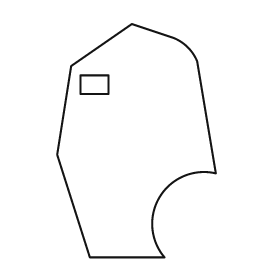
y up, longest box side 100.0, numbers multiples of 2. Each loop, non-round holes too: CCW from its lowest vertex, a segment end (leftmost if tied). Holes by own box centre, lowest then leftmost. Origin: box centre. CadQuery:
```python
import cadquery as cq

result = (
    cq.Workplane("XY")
    .moveTo(-20.0, -50.0)
    .lineTo(12.0, -50.0)
    .threePointArc((10.0, -24.0), (34.0, -14.0))
    .lineTo(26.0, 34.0)
    .threePointArc((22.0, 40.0), (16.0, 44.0))
    .lineTo(-2.0, 50.0)
    .lineTo(-28.0, 32.0)
    .lineTo(-34.0, -6.0)
    .close()
    .moveTo(-24.0, 20.0)
    .lineTo(-12.0, 20.0)
    .lineTo(-12.0, 28.0)
    .lineTo(-24.0, 28.0)
    .close()
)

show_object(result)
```